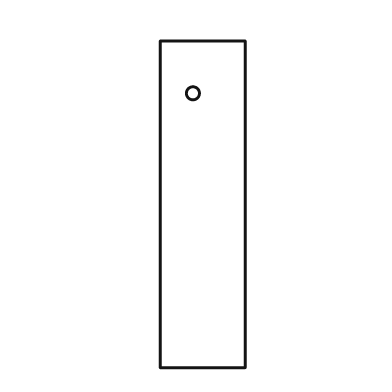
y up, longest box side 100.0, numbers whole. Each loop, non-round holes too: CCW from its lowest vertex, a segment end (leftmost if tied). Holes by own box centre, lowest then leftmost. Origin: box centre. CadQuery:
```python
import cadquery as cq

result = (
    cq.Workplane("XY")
    .moveTo(-13.0, -50.0)
    .lineTo(13.0, -50.0)
    .lineTo(13.0, 50.0)
    .lineTo(-13.0, 50.0)
    .close()
    .moveTo(-3.0, 34.0)
    .circle(2.0)
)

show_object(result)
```